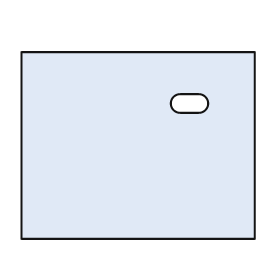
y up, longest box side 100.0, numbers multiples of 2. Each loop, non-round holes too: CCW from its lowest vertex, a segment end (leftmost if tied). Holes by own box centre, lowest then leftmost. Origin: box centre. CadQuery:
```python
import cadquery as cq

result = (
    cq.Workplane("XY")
    .moveTo(-50.0, -40.0)
    .lineTo(50.0, -40.0)
    .lineTo(50.0, 40.0)
    .lineTo(-50.0, 40.0)
    .close()
    .moveTo(18.0, 14.0)
    .lineTo(26.0, 14.0)
    .threePointArc((30.0, 18.0), (26.0, 22.0))
    .lineTo(18.0, 22.0)
    .threePointArc((14.0, 18.0), (18.0, 14.0))
    .close()
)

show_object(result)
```